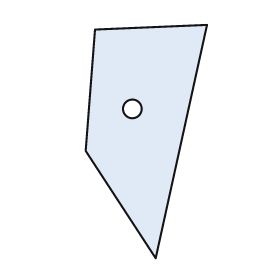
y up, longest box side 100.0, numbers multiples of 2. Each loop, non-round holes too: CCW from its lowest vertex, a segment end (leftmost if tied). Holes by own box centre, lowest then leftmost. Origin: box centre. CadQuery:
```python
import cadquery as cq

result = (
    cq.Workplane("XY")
    .moveTo(4.0, -50.0)
    .lineTo(26.0, 50.0)
    .lineTo(-22.0, 48.0)
    .lineTo(-26.0, -4.0)
    .close()
    .moveTo(-6.0, 14.0)
    .circle(4.0)
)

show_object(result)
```